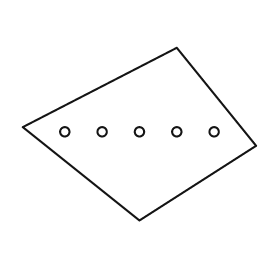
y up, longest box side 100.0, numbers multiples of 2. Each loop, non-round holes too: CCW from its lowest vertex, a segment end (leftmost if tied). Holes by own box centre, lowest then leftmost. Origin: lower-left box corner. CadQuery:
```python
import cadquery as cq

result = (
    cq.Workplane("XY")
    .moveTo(50.0, 0.0)
    .lineTo(100.0, 32.0)
    .lineTo(66.0, 74.0)
    .lineTo(0.0, 40.0)
    .close()
    .moveTo(18.0, 38.0)
    .circle(2.0)
    .moveTo(34.0, 38.0)
    .circle(2.0)
    .moveTo(50.0, 38.0)
    .circle(2.0)
    .moveTo(66.0, 38.0)
    .circle(2.0)
    .moveTo(82.0, 38.0)
    .circle(2.0)
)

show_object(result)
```